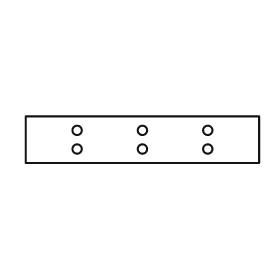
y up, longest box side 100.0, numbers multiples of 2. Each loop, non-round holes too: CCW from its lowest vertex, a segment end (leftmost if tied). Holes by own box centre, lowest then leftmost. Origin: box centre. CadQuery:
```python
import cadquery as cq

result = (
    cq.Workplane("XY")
    .moveTo(-50.0, -10.0)
    .lineTo(50.0, -10.0)
    .lineTo(50.0, 10.0)
    .lineTo(-50.0, 10.0)
    .close()
    .moveTo(-28.0, -4.0)
    .circle(2.0)
    .moveTo(0.0, -4.0)
    .circle(2.0)
    .moveTo(28.0, -4.0)
    .circle(2.0)
    .moveTo(-28.0, 4.0)
    .circle(2.0)
    .moveTo(0.0, 4.0)
    .circle(2.0)
    .moveTo(28.0, 4.0)
    .circle(2.0)
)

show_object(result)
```